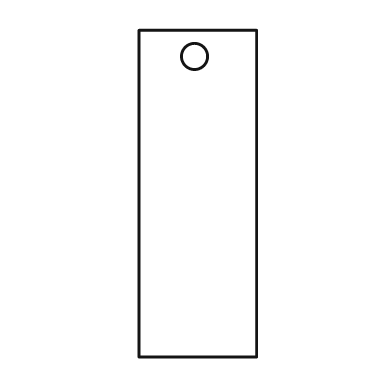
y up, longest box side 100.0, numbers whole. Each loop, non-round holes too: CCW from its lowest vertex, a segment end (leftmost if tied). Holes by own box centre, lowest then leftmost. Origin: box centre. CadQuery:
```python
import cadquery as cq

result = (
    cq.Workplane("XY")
    .moveTo(-18.0, -50.0)
    .lineTo(18.0, -50.0)
    .lineTo(18.0, 50.0)
    .lineTo(-18.0, 50.0)
    .close()
    .moveTo(-1.0, 42.0)
    .circle(4.0)
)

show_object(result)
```